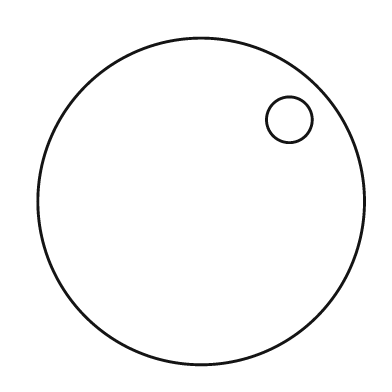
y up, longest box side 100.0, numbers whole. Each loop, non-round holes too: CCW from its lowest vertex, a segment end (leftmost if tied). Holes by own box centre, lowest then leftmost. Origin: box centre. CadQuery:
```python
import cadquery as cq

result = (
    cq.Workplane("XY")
    .moveTo(0.0, 0.0)
    .circle(50.0)
    .moveTo(27.0, 25.0)
    .circle(7.0)
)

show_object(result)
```